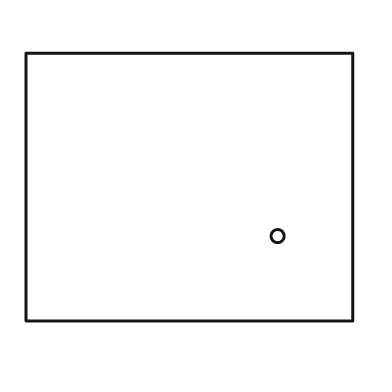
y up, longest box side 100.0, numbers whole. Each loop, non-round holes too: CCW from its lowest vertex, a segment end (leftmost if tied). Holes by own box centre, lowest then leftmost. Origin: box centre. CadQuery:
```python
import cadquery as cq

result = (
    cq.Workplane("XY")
    .moveTo(-50.0, -41.0)
    .lineTo(50.0, -41.0)
    .lineTo(50.0, 41.0)
    .lineTo(-50.0, 41.0)
    .close()
    .moveTo(27.0, -15.0)
    .circle(2.0)
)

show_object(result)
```